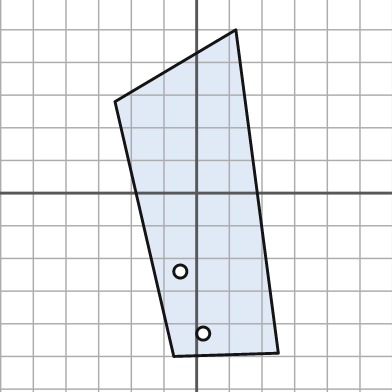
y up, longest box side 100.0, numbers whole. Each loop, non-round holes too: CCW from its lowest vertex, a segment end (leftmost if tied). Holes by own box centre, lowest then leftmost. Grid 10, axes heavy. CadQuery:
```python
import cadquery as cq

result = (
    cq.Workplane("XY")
    .moveTo(-7.0, -50.0)
    .lineTo(25.0, -49.0)
    .lineTo(12.0, 50.0)
    .lineTo(-25.0, 28.0)
    .close()
    .moveTo(2.0, -43.0)
    .circle(2.0)
    .moveTo(-5.0, -24.0)
    .circle(2.0)
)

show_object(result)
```